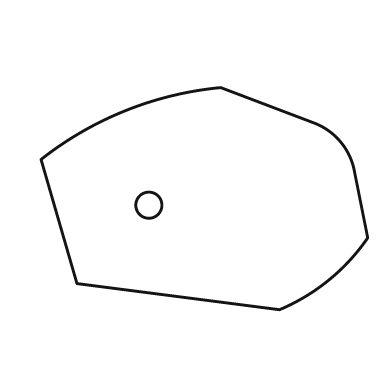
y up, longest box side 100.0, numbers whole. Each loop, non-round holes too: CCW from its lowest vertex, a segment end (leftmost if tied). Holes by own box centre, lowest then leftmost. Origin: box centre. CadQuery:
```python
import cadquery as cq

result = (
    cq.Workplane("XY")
    .moveTo(23.0, -34.0)
    .threePointArc((38.0, -25.0), (50.0, -12.0))
    .lineTo(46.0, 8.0)
    .threePointArc((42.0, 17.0), (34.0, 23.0))
    .lineTo(5.0, 34.0)
    .threePointArc((-24.0, 27.0), (-50.0, 12.0))
    .lineTo(-39.0, -26.0)
    .close()
    .moveTo(-17.0, -2.0)
    .circle(4.0)
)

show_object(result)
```